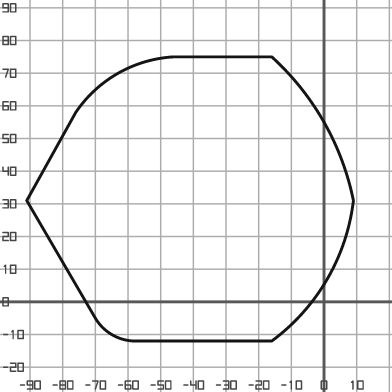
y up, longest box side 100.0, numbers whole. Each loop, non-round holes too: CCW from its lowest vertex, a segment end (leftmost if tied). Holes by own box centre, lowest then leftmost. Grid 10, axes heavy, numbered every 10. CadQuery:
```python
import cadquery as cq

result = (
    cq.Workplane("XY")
    .moveTo(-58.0, -12.0)
    .lineTo(-16.0, -12.0)
    .threePointArc((1.0, 7.0), (9.0, 31.0))
    .threePointArc((0.0, 55.0), (-16.0, 75.0))
    .lineTo(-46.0, 75.0)
    .threePointArc((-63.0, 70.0), (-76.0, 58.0))
    .lineTo(-91.0, 31.0)
    .lineTo(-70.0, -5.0)
    .threePointArc((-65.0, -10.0), (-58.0, -12.0))
    .close()
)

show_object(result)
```